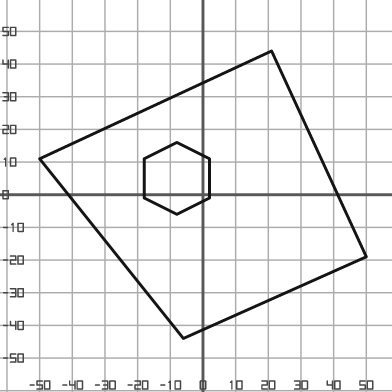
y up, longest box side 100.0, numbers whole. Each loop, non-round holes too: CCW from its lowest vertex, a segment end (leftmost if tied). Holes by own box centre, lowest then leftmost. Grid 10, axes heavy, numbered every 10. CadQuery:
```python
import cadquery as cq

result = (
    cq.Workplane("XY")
    .moveTo(-6.0, -44.0)
    .lineTo(50.0, -19.0)
    .lineTo(21.0, 44.0)
    .lineTo(-50.0, 11.0)
    .close()
    .moveTo(-8.0, -6.0)
    .lineTo(2.0, -1.0)
    .lineTo(2.0, 11.0)
    .lineTo(-8.0, 16.0)
    .lineTo(-18.0, 11.0)
    .lineTo(-18.0, -1.0)
    .close()
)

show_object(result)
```